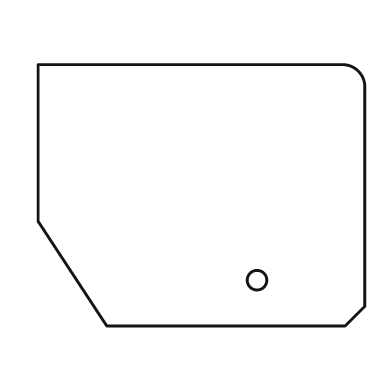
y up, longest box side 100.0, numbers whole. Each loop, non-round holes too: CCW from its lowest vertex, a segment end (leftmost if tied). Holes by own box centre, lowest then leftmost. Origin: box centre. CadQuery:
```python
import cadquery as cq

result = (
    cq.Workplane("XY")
    .moveTo(-29.0, -40.0)
    .lineTo(44.0, -40.0)
    .lineTo(50.0, -34.0)
    .lineTo(50.0, 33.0)
    .threePointArc((48.0, 38.0), (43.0, 40.0))
    .lineTo(-50.0, 40.0)
    .lineTo(-50.0, -8.0)
    .close()
    .moveTo(17.0, -26.0)
    .circle(3.0)
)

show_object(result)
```